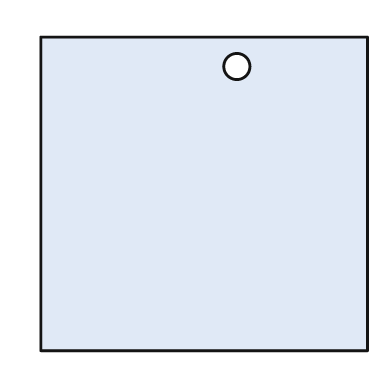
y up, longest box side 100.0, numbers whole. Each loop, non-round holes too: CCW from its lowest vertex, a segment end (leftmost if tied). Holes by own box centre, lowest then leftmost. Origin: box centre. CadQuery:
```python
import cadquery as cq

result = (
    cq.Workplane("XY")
    .moveTo(-50.0, -48.0)
    .lineTo(50.0, -48.0)
    .lineTo(50.0, 48.0)
    .lineTo(-50.0, 48.0)
    .close()
    .moveTo(10.0, 39.0)
    .circle(4.0)
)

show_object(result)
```